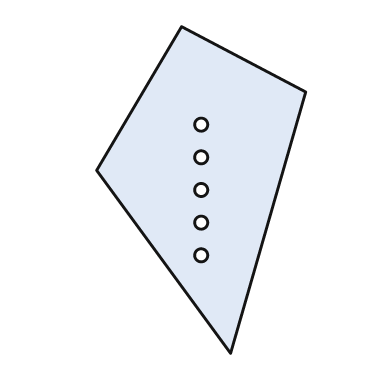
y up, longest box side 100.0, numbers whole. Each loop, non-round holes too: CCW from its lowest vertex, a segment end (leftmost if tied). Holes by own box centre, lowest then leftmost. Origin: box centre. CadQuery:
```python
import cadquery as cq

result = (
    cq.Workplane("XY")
    .moveTo(9.0, -50.0)
    .lineTo(32.0, 30.0)
    .lineTo(-6.0, 50.0)
    .lineTo(-32.0, 6.0)
    .close()
    .moveTo(0.0, -20.0)
    .circle(2.0)
    .moveTo(0.0, -10.0)
    .circle(2.0)
    .moveTo(0.0, 0.0)
    .circle(2.0)
    .moveTo(0.0, 10.0)
    .circle(2.0)
    .moveTo(0.0, 20.0)
    .circle(2.0)
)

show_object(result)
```